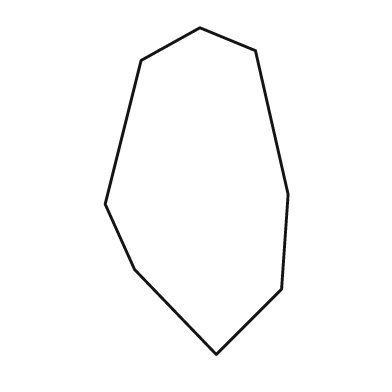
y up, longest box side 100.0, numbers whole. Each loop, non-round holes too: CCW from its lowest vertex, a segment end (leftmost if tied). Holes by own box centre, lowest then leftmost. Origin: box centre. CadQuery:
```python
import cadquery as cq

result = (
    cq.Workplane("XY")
    .moveTo(6.0, -50.0)
    .lineTo(26.0, -30.0)
    .lineTo(28.0, -1.0)
    .lineTo(18.0, 43.0)
    .lineTo(1.0, 50.0)
    .lineTo(-17.0, 40.0)
    .lineTo(-28.0, -4.0)
    .lineTo(-19.0, -24.0)
    .close()
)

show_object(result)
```